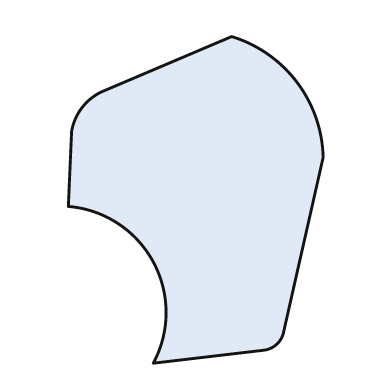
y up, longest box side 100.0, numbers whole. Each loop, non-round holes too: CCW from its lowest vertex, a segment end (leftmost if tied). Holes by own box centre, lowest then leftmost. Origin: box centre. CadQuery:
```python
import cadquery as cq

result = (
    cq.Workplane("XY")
    .moveTo(-13.0, -50.0)
    .lineTo(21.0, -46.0)
    .threePointArc((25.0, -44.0), (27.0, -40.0))
    .lineTo(39.0, 13.0)
    .threePointArc((31.0, 36.0), (11.0, 50.0))
    .lineTo(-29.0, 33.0)
    .threePointArc((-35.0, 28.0), (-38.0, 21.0))
    .lineTo(-39.0, -2.0)
    .threePointArc((-13.0, -19.0), (-13.0, -50.0))
    .close()
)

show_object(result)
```